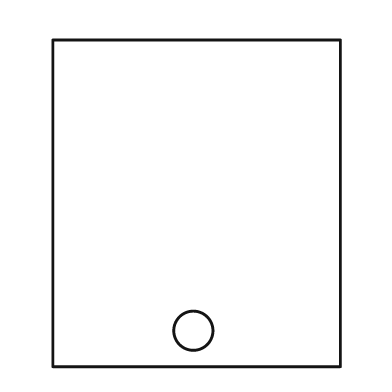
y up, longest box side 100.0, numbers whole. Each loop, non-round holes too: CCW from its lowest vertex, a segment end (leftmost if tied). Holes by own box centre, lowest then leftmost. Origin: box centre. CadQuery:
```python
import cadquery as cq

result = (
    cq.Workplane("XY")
    .moveTo(-44.0, -50.0)
    .lineTo(44.0, -50.0)
    .lineTo(44.0, 50.0)
    .lineTo(-44.0, 50.0)
    .close()
    .moveTo(-1.0, -39.0)
    .circle(6.0)
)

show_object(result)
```